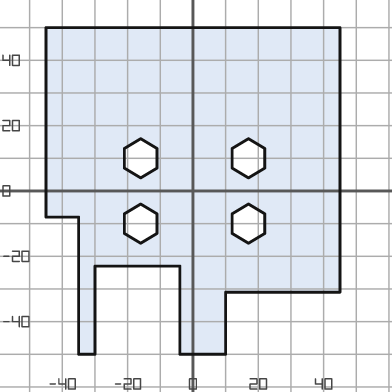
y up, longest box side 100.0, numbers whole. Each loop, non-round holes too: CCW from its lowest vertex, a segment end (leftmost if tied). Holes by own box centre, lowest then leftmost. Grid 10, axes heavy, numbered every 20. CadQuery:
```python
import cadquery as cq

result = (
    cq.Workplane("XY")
    .moveTo(-35.0, -50.0)
    .lineTo(-30.0, -50.0)
    .lineTo(-30.0, -23.0)
    .lineTo(-4.0, -23.0)
    .lineTo(-4.0, -50.0)
    .lineTo(10.0, -50.0)
    .lineTo(10.0, -31.0)
    .lineTo(45.0, -31.0)
    .lineTo(45.0, 50.0)
    .lineTo(-45.0, 50.0)
    .lineTo(-45.0, -8.0)
    .lineTo(-35.0, -8.0)
    .close()
    .moveTo(-16.0, -16.0)
    .lineTo(-11.0, -13.0)
    .lineTo(-11.0, -7.0)
    .lineTo(-16.0, -4.0)
    .lineTo(-21.0, -7.0)
    .lineTo(-21.0, -13.0)
    .close()
    .moveTo(17.0, -16.0)
    .lineTo(22.0, -13.0)
    .lineTo(22.0, -7.0)
    .lineTo(17.0, -4.0)
    .lineTo(12.0, -7.0)
    .lineTo(12.0, -13.0)
    .close()
    .moveTo(-16.0, 4.0)
    .lineTo(-11.0, 7.0)
    .lineTo(-11.0, 13.0)
    .lineTo(-16.0, 16.0)
    .lineTo(-21.0, 13.0)
    .lineTo(-21.0, 7.0)
    .close()
    .moveTo(17.0, 4.0)
    .lineTo(22.0, 7.0)
    .lineTo(22.0, 13.0)
    .lineTo(17.0, 16.0)
    .lineTo(12.0, 13.0)
    .lineTo(12.0, 7.0)
    .close()
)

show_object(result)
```